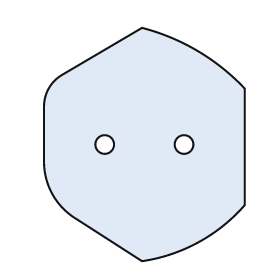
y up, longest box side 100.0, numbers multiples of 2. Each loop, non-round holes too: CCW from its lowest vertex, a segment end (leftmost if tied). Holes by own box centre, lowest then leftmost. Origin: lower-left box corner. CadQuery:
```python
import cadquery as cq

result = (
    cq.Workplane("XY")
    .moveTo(42.0, 0.0)
    .threePointArc((66.0, 8.0), (86.0, 24.0))
    .lineTo(86.0, 74.0)
    .threePointArc((66.0, 90.0), (42.0, 100.0))
    .lineTo(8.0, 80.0)
    .threePointArc((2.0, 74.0), (0.0, 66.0))
    .lineTo(0.0, 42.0)
    .threePointArc((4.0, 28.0), (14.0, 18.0))
    .close()
    .moveTo(26.0, 50.0)
    .circle(4.0)
    .moveTo(60.0, 50.0)
    .circle(4.0)
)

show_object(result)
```